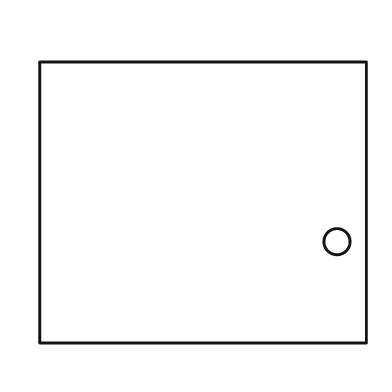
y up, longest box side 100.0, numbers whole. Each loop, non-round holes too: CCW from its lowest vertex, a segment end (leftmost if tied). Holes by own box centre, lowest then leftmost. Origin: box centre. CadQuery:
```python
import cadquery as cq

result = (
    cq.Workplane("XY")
    .moveTo(-50.0, -43.0)
    .lineTo(50.0, -43.0)
    .lineTo(50.0, 43.0)
    .lineTo(-50.0, 43.0)
    .close()
    .moveTo(41.0, -12.0)
    .circle(4.0)
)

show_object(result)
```